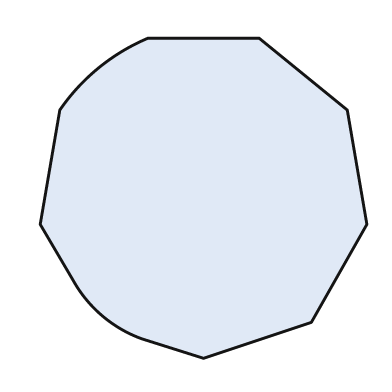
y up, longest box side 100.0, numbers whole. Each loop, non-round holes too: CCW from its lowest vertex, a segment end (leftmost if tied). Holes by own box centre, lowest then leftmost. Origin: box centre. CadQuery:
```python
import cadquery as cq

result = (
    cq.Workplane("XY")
    .moveTo(0.0, -49.0)
    .lineTo(33.0, -38.0)
    .lineTo(50.0, -8.0)
    .lineTo(44.0, 27.0)
    .lineTo(17.0, 49.0)
    .lineTo(-17.0, 49.0)
    .threePointArc((-32.0, 40.0), (-44.0, 27.0))
    .lineTo(-50.0, -8.0)
    .lineTo(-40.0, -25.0)
    .threePointArc((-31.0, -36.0), (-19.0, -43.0))
    .close()
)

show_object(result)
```